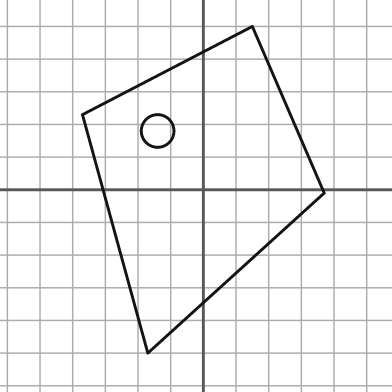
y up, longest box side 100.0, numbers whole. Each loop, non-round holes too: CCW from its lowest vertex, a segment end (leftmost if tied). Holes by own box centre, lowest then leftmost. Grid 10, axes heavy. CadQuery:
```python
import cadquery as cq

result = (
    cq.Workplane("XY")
    .moveTo(-17.0, -50.0)
    .lineTo(37.0, -1.0)
    .lineTo(15.0, 50.0)
    .lineTo(-37.0, 23.0)
    .close()
    .moveTo(-14.0, 18.0)
    .circle(5.0)
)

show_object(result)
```